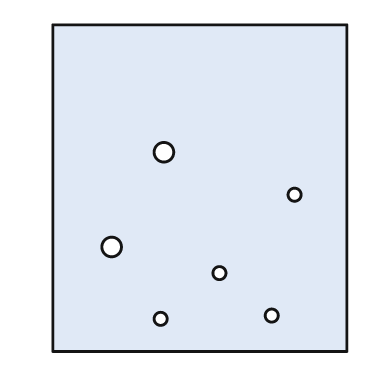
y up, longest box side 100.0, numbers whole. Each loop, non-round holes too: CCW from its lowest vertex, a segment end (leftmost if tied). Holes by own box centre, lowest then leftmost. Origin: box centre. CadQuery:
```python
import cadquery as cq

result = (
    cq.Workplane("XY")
    .moveTo(-45.0, -50.0)
    .lineTo(45.0, -50.0)
    .lineTo(45.0, 50.0)
    .lineTo(-45.0, 50.0)
    .close()
    .moveTo(-12.0, -40.0)
    .circle(2.0)
    .moveTo(22.0, -39.0)
    .circle(2.0)
    .moveTo(6.0, -26.0)
    .circle(2.0)
    .moveTo(-27.0, -18.0)
    .circle(3.0)
    .moveTo(29.0, -2.0)
    .circle(2.0)
    .moveTo(-11.0, 11.0)
    .circle(3.0)
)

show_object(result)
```